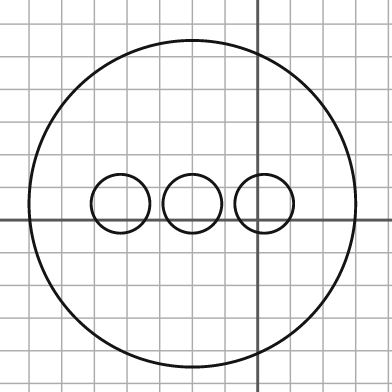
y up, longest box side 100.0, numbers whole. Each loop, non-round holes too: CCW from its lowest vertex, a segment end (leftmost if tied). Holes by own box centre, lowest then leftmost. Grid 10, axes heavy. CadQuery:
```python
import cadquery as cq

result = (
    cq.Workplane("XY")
    .moveTo(-20.0, 5.0)
    .circle(50.0)
    .moveTo(-42.0, 5.0)
    .circle(9.0)
    .moveTo(-20.0, 5.0)
    .circle(9.0)
    .moveTo(2.0, 5.0)
    .circle(9.0)
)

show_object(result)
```